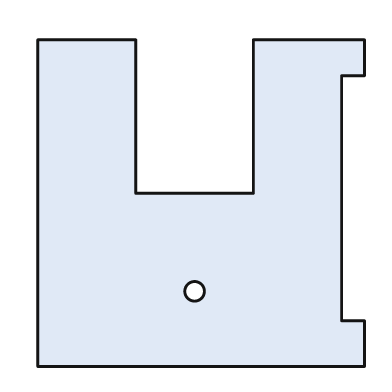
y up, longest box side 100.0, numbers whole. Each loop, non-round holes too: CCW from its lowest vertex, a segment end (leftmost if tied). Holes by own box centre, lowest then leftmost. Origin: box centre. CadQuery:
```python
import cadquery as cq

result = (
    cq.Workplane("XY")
    .moveTo(-50.0, -50.0)
    .lineTo(50.0, -50.0)
    .lineTo(50.0, -36.0)
    .lineTo(43.0, -36.0)
    .lineTo(43.0, 39.0)
    .lineTo(50.0, 39.0)
    .lineTo(50.0, 50.0)
    .lineTo(16.0, 50.0)
    .lineTo(16.0, 3.0)
    .lineTo(-20.0, 3.0)
    .lineTo(-20.0, 50.0)
    .lineTo(-50.0, 50.0)
    .close()
    .moveTo(-2.0, -27.0)
    .circle(3.0)
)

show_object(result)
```